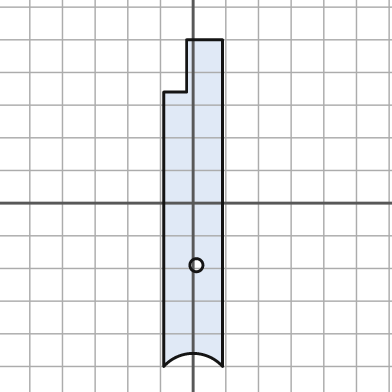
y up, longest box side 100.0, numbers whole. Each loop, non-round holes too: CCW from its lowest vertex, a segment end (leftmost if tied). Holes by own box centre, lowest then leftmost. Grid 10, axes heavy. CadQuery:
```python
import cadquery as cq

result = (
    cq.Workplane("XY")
    .moveTo(-9.0, -50.0)
    .threePointArc((0.0, -46.0), (9.0, -50.0))
    .lineTo(9.0, 50.0)
    .lineTo(-2.0, 50.0)
    .lineTo(-2.0, 34.0)
    .lineTo(-9.0, 34.0)
    .close()
    .moveTo(1.0, -19.0)
    .circle(2.0)
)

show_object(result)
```